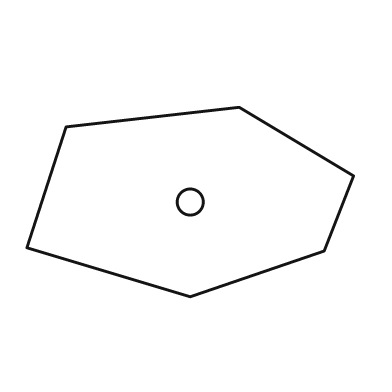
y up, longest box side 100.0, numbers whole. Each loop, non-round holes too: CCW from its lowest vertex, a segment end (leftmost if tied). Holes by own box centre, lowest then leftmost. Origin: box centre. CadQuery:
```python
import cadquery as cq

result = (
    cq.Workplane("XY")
    .moveTo(0.0, -29.0)
    .lineTo(41.0, -15.0)
    .lineTo(50.0, 8.0)
    .lineTo(15.0, 29.0)
    .lineTo(-38.0, 23.0)
    .lineTo(-50.0, -14.0)
    .close()
    .moveTo(0.0, 0.0)
    .circle(4.0)
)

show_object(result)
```